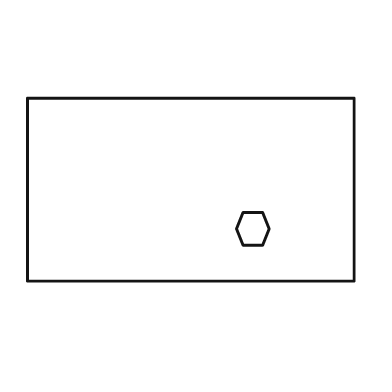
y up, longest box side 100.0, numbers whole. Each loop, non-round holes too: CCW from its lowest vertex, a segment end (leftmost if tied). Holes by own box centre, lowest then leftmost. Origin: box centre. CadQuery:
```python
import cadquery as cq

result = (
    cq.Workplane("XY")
    .moveTo(-50.0, -28.0)
    .lineTo(50.0, -28.0)
    .lineTo(50.0, 28.0)
    .lineTo(-50.0, 28.0)
    .close()
    .moveTo(16.0, -17.0)
    .lineTo(22.0, -17.0)
    .lineTo(24.0, -12.0)
    .lineTo(22.0, -7.0)
    .lineTo(16.0, -7.0)
    .lineTo(14.0, -12.0)
    .close()
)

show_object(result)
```